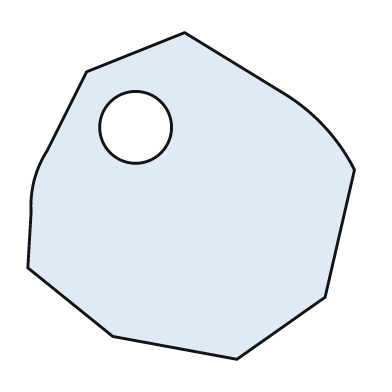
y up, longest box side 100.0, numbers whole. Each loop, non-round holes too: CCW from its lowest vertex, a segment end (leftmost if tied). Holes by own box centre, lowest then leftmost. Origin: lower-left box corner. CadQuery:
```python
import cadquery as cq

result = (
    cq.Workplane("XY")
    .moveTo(64.0, 0.0)
    .lineTo(91.0, 19.0)
    .lineTo(100.0, 58.0)
    .threePointArc((91.0, 71.0), (79.0, 81.0))
    .lineTo(48.0, 100.0)
    .lineTo(18.0, 88.0)
    .lineTo(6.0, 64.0)
    .threePointArc((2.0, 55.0), (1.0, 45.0))
    .lineTo(0.0, 28.0)
    .lineTo(26.0, 7.0)
    .close()
    .moveTo(33.0, 71.0)
    .circle(11.0)
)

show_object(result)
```